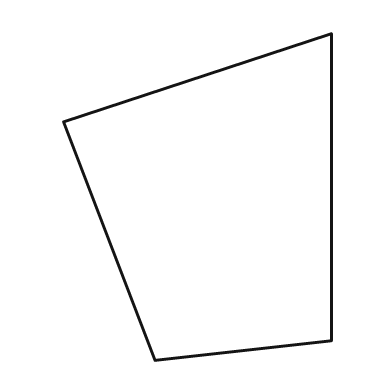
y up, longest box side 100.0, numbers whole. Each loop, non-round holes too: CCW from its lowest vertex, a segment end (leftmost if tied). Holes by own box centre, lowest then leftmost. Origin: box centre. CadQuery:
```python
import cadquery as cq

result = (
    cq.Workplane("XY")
    .moveTo(-13.0, -50.0)
    .lineTo(41.0, -44.0)
    .lineTo(41.0, 50.0)
    .lineTo(-41.0, 23.0)
    .close()
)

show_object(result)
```